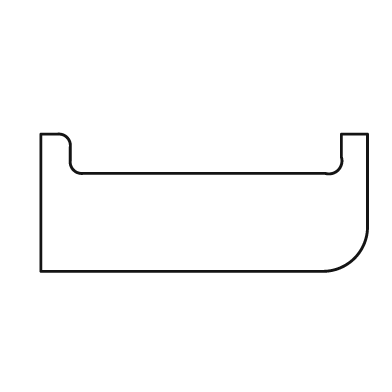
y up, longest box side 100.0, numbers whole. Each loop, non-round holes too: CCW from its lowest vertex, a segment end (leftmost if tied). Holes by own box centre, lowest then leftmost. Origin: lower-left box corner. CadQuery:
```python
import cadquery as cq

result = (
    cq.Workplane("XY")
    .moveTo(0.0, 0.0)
    .lineTo(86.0, 0.0)
    .threePointArc((96.0, 4.0), (100.0, 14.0))
    .lineTo(100.0, 42.0)
    .lineTo(92.0, 42.0)
    .lineTo(92.0, 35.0)
    .threePointArc((91.0, 31.0), (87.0, 30.0))
    .lineTo(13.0, 30.0)
    .threePointArc((10.0, 31.0), (9.0, 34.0))
    .lineTo(9.0, 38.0)
    .threePointArc((8.0, 41.0), (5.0, 42.0))
    .lineTo(0.0, 42.0)
    .close()
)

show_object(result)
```